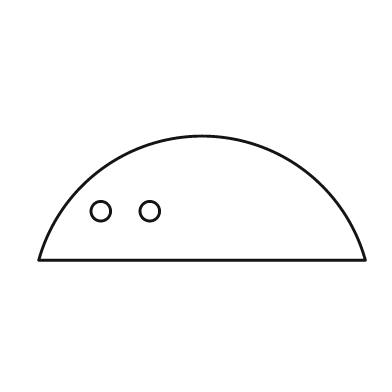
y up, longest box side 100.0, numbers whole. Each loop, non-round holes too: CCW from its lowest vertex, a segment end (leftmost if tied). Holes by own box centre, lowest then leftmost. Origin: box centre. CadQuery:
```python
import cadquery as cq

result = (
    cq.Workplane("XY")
    .moveTo(-50.0, -19.0)
    .lineTo(50.0, -19.0)
    .threePointArc((0.0, 19.0), (-50.0, -19.0))
    .close()
    .moveTo(-31.0, -4.0)
    .circle(3.0)
    .moveTo(-16.0, -4.0)
    .circle(3.0)
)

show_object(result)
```